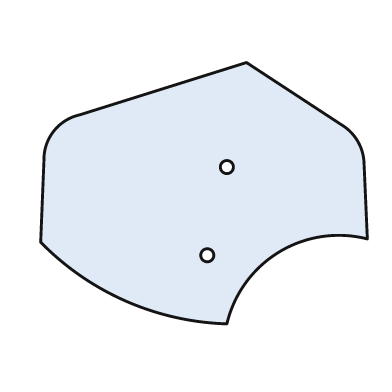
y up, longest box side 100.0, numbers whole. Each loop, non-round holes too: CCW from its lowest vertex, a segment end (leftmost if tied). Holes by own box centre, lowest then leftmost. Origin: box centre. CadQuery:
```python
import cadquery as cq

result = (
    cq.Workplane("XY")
    .moveTo(7.0, -40.0)
    .threePointArc((23.0, -18.0), (50.0, -14.0))
    .lineTo(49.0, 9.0)
    .threePointArc((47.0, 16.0), (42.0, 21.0))
    .lineTo(13.0, 40.0)
    .lineTo(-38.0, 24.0)
    .threePointArc((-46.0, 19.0), (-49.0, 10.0))
    .lineTo(-50.0, -15.0)
    .threePointArc((-24.0, -33.0), (7.0, -40.0))
    .close()
    .moveTo(1.0, -19.0)
    .circle(2.0)
    .moveTo(7.0, 8.0)
    .circle(2.0)
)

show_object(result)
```